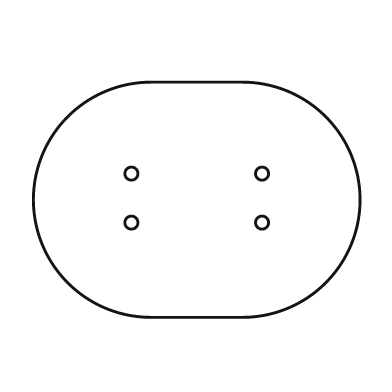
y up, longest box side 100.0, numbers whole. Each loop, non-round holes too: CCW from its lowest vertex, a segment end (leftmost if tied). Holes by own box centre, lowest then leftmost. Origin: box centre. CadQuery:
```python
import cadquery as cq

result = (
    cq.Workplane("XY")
    .moveTo(-14.0, -36.0)
    .lineTo(14.0, -36.0)
    .threePointArc((50.0, 0.0), (14.0, 36.0))
    .lineTo(-14.0, 36.0)
    .threePointArc((-50.0, 0.0), (-14.0, -36.0))
    .close()
    .moveTo(-20.0, -7.0)
    .circle(2.0)
    .moveTo(20.0, -7.0)
    .circle(2.0)
    .moveTo(-20.0, 8.0)
    .circle(2.0)
    .moveTo(20.0, 8.0)
    .circle(2.0)
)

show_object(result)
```